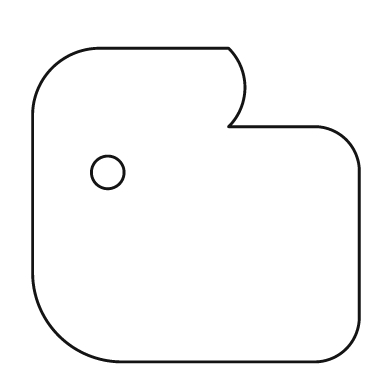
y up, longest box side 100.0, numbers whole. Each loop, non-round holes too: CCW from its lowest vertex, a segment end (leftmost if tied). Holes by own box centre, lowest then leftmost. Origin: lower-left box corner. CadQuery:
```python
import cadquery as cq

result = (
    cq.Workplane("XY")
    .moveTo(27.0, 0.0)
    .lineTo(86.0, 0.0)
    .threePointArc((96.0, 4.0), (100.0, 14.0))
    .lineTo(100.0, 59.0)
    .threePointArc((96.0, 68.0), (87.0, 72.0))
    .lineTo(60.0, 72.0)
    .threePointArc((65.0, 84.0), (60.0, 96.0))
    .lineTo(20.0, 96.0)
    .threePointArc((6.0, 90.0), (0.0, 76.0))
    .lineTo(0.0, 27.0)
    .threePointArc((8.0, 8.0), (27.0, 0.0))
    .close()
    .moveTo(23.0, 58.0)
    .circle(5.0)
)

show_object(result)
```